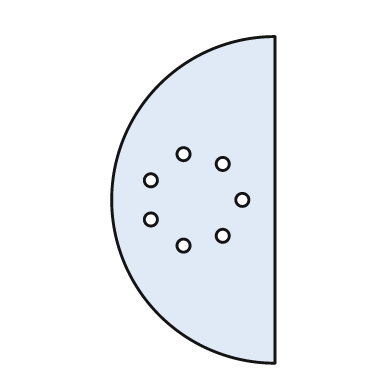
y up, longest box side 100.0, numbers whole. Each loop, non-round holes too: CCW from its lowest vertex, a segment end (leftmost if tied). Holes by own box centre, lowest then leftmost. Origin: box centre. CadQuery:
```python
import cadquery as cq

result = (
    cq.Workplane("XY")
    .moveTo(25.0, -50.0)
    .lineTo(25.0, 50.0)
    .threePointArc((-25.0, 0.0), (25.0, -50.0))
    .close()
    .moveTo(-3.0, -14.0)
    .circle(2.0)
    .moveTo(9.0, -11.0)
    .circle(2.0)
    .moveTo(-13.0, -6.0)
    .circle(2.0)
    .moveTo(15.0, 0.0)
    .circle(2.0)
    .moveTo(-13.0, 6.0)
    .circle(2.0)
    .moveTo(9.0, 11.0)
    .circle(2.0)
    .moveTo(-3.0, 14.0)
    .circle(2.0)
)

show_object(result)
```